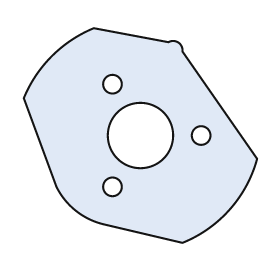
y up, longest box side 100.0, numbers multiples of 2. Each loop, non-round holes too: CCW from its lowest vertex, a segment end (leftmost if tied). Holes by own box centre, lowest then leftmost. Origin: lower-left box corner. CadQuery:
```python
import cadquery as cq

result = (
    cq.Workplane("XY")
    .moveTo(68.0, 0.0)
    .threePointArc((88.0, 14.0), (100.0, 36.0))
    .lineTo(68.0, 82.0)
    .threePointArc((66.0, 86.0), (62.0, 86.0))
    .lineTo(30.0, 92.0)
    .threePointArc((12.0, 80.0), (0.0, 62.0))
    .lineTo(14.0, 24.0)
    .threePointArc((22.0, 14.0), (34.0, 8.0))
    .close()
    .moveTo(38.0, 24.0)
    .circle(4.0)
    .moveTo(50.0, 46.0)
    .circle(14.0)
    .moveTo(76.0, 46.0)
    .circle(4.0)
    .moveTo(38.0, 68.0)
    .circle(4.0)
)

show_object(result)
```